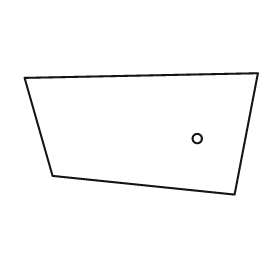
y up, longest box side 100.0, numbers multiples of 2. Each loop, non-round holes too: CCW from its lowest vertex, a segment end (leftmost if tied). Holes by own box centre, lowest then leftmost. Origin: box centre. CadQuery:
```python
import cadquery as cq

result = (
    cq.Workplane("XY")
    .moveTo(40.0, -26.0)
    .lineTo(50.0, 26.0)
    .lineTo(-50.0, 24.0)
    .lineTo(-38.0, -18.0)
    .close()
    .moveTo(24.0, -2.0)
    .circle(2.0)
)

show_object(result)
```